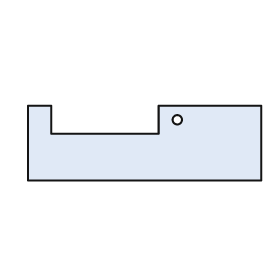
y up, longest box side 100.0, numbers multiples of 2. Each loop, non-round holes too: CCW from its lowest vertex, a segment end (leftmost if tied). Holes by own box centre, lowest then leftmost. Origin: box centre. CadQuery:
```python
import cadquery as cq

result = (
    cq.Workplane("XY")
    .moveTo(-50.0, -16.0)
    .lineTo(50.0, -16.0)
    .lineTo(50.0, 16.0)
    .lineTo(6.0, 16.0)
    .lineTo(6.0, 4.0)
    .lineTo(-40.0, 4.0)
    .lineTo(-40.0, 16.0)
    .lineTo(-50.0, 16.0)
    .close()
    .moveTo(14.0, 10.0)
    .circle(2.0)
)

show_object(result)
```